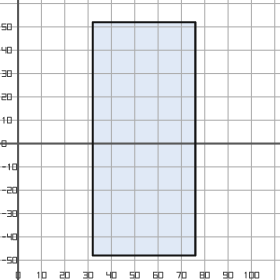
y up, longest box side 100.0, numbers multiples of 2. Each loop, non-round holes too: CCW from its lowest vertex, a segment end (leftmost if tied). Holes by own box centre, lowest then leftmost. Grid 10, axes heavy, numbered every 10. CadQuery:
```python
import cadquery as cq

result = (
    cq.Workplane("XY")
    .moveTo(32.0, -48.0)
    .lineTo(76.0, -48.0)
    .lineTo(76.0, 52.0)
    .lineTo(32.0, 52.0)
    .close()
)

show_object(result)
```